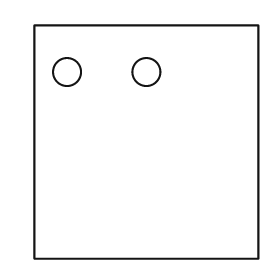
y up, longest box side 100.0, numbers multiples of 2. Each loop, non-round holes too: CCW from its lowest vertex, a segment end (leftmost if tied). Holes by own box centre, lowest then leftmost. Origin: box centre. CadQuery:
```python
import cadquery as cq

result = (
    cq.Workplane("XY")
    .moveTo(-48.0, -50.0)
    .lineTo(48.0, -50.0)
    .lineTo(48.0, 50.0)
    .lineTo(-48.0, 50.0)
    .close()
    .moveTo(-34.0, 30.0)
    .circle(6.0)
    .moveTo(0.0, 30.0)
    .circle(6.0)
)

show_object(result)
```